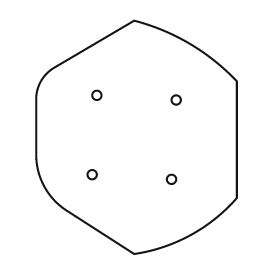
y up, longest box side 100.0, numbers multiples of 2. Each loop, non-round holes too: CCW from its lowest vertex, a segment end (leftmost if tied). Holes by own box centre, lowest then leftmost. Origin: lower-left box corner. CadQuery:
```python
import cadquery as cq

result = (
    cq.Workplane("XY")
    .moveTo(42.0, 0.0)
    .threePointArc((66.0, 8.0), (86.0, 24.0))
    .lineTo(86.0, 74.0)
    .threePointArc((66.0, 90.0), (42.0, 100.0))
    .lineTo(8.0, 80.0)
    .threePointArc((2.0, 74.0), (0.0, 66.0))
    .lineTo(0.0, 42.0)
    .threePointArc((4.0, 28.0), (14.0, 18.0))
    .close()
    .moveTo(58.0, 32.0)
    .circle(2.0)
    .moveTo(24.0, 34.0)
    .circle(2.0)
    .moveTo(60.0, 66.0)
    .circle(2.0)
    .moveTo(26.0, 68.0)
    .circle(2.0)
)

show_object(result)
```